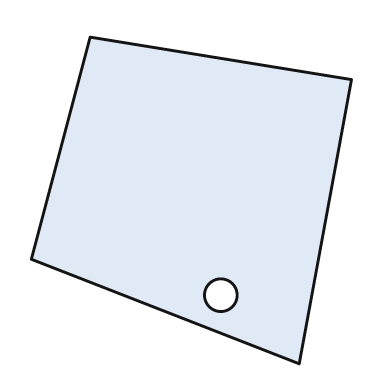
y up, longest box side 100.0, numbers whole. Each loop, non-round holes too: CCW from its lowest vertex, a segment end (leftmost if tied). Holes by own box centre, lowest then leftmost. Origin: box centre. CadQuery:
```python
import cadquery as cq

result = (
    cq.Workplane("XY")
    .moveTo(33.0, -50.0)
    .lineTo(49.0, 37.0)
    .lineTo(-31.0, 50.0)
    .lineTo(-49.0, -18.0)
    .close()
    .moveTo(9.0, -29.0)
    .circle(5.0)
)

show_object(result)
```